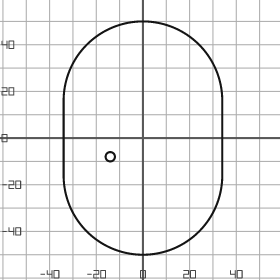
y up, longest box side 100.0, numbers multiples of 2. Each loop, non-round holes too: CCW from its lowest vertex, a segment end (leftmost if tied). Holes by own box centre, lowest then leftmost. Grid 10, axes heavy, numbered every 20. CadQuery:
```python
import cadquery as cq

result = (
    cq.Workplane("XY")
    .moveTo(-34.0, -16.0)
    .threePointArc((0.0, -50.0), (34.0, -16.0))
    .lineTo(34.0, 16.0)
    .threePointArc((0.0, 50.0), (-34.0, 16.0))
    .close()
    .moveTo(-14.0, -8.0)
    .circle(2.0)
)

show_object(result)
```